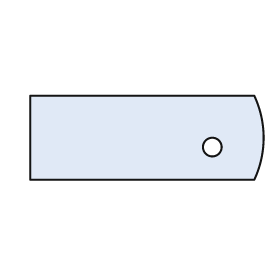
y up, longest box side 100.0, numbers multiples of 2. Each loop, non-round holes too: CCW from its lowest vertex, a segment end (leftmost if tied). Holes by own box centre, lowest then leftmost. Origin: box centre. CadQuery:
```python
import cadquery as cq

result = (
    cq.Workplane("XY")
    .moveTo(-50.0, -18.0)
    .lineTo(46.0, -18.0)
    .threePointArc((50.0, 0.0), (46.0, 18.0))
    .lineTo(-50.0, 18.0)
    .close()
    .moveTo(28.0, -4.0)
    .circle(4.0)
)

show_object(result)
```